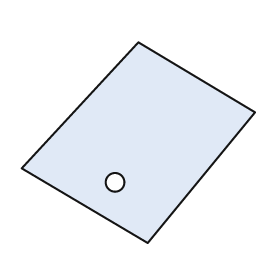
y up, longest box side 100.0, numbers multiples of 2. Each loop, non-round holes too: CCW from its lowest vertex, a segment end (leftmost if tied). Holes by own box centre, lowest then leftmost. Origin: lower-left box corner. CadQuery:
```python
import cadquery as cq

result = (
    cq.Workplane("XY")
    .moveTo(54.0, 0.0)
    .lineTo(100.0, 56.0)
    .lineTo(50.0, 86.0)
    .lineTo(0.0, 32.0)
    .close()
    .moveTo(40.0, 26.0)
    .circle(4.0)
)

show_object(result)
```